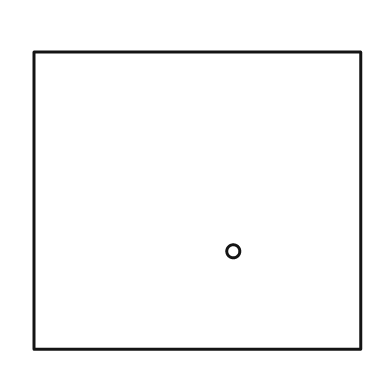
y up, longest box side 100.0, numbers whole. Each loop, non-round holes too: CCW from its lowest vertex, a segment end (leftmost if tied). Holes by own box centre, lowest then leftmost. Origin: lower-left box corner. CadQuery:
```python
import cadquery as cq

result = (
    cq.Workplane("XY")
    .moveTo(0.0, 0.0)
    .lineTo(100.0, 0.0)
    .lineTo(100.0, 91.0)
    .lineTo(0.0, 91.0)
    .close()
    .moveTo(61.0, 30.0)
    .circle(2.0)
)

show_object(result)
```